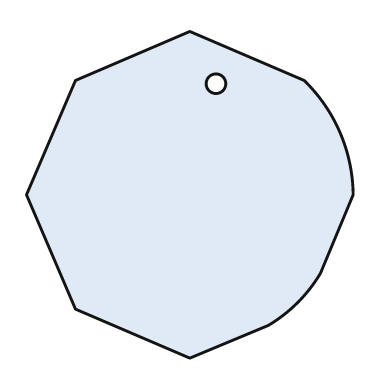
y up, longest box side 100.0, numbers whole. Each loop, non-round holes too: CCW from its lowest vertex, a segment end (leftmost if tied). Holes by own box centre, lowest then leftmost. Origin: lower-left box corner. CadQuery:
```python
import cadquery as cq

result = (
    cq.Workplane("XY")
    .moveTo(50.0, 0.0)
    .lineTo(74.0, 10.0)
    .threePointArc((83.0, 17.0), (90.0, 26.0))
    .lineTo(100.0, 50.0)
    .threePointArc((96.0, 69.0), (85.0, 85.0))
    .lineTo(50.0, 100.0)
    .lineTo(15.0, 85.0)
    .lineTo(0.0, 50.0)
    .lineTo(15.0, 15.0)
    .close()
    .moveTo(58.0, 84.0)
    .circle(3.0)
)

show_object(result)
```